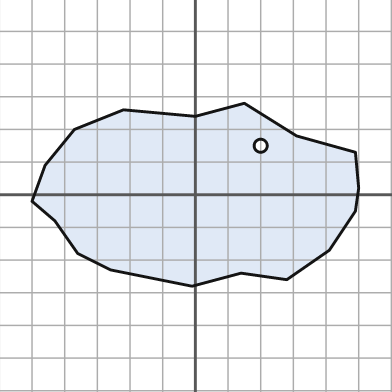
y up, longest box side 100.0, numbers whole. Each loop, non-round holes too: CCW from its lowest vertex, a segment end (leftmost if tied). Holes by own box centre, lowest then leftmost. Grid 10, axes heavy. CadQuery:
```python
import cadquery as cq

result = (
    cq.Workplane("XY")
    .moveTo(-1.0, -28.0)
    .lineTo(14.0, -24.0)
    .lineTo(28.0, -26.0)
    .lineTo(41.0, -17.0)
    .lineTo(49.0, -5.0)
    .lineTo(50.0, 2.0)
    .lineTo(49.0, 13.0)
    .lineTo(31.0, 18.0)
    .lineTo(15.0, 28.0)
    .lineTo(0.0, 24.0)
    .lineTo(-22.0, 26.0)
    .lineTo(-37.0, 20.0)
    .lineTo(-46.0, 9.0)
    .lineTo(-50.0, -2.0)
    .lineTo(-43.0, -8.0)
    .lineTo(-36.0, -18.0)
    .lineTo(-26.0, -23.0)
    .close()
    .moveTo(20.0, 15.0)
    .circle(2.0)
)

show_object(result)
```